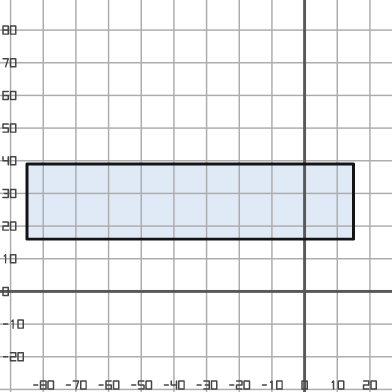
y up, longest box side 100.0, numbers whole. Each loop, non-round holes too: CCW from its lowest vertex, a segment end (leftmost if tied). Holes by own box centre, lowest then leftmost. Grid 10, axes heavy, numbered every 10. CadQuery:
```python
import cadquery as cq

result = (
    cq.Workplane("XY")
    .moveTo(-85.0, 16.0)
    .lineTo(15.0, 16.0)
    .lineTo(15.0, 39.0)
    .lineTo(-85.0, 39.0)
    .close()
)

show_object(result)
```